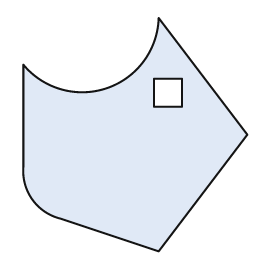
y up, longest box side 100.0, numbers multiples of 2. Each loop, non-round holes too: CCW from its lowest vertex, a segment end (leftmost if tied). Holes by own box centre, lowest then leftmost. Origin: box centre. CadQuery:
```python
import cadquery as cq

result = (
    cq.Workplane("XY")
    .moveTo(10.0, -50.0)
    .lineTo(48.0, 0.0)
    .lineTo(10.0, 50.0)
    .threePointArc((-12.0, 20.0), (-48.0, 30.0))
    .lineTo(-48.0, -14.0)
    .threePointArc((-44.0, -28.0), (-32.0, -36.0))
    .close()
    .moveTo(8.0, 12.0)
    .lineTo(20.0, 12.0)
    .lineTo(20.0, 24.0)
    .lineTo(8.0, 24.0)
    .close()
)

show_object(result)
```